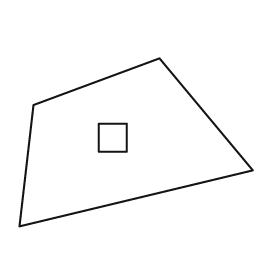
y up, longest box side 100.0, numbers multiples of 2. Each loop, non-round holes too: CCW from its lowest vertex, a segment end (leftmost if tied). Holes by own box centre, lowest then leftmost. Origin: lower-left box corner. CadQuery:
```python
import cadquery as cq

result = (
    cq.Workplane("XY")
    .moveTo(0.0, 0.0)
    .lineTo(100.0, 24.0)
    .lineTo(60.0, 72.0)
    .lineTo(6.0, 52.0)
    .close()
    .moveTo(34.0, 32.0)
    .lineTo(46.0, 32.0)
    .lineTo(46.0, 44.0)
    .lineTo(34.0, 44.0)
    .close()
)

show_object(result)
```